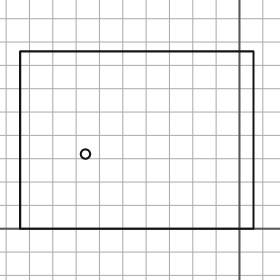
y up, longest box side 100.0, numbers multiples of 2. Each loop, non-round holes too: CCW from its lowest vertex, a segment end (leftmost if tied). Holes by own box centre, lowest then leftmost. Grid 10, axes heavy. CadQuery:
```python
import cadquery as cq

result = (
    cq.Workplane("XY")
    .moveTo(-94.0, 0.0)
    .lineTo(6.0, 0.0)
    .lineTo(6.0, 76.0)
    .lineTo(-94.0, 76.0)
    .close()
    .moveTo(-66.0, 32.0)
    .circle(2.0)
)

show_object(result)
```